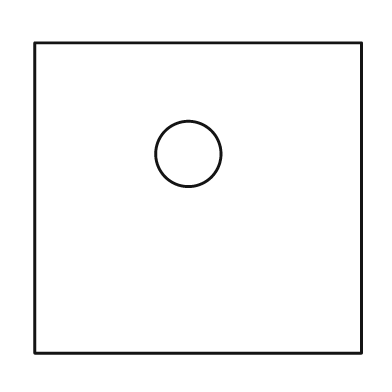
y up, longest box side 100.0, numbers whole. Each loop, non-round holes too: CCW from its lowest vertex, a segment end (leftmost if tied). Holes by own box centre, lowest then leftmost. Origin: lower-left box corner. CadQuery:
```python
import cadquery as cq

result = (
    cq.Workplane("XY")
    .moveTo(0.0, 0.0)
    .lineTo(100.0, 0.0)
    .lineTo(100.0, 95.0)
    .lineTo(0.0, 95.0)
    .close()
    .moveTo(47.0, 61.0)
    .circle(10.0)
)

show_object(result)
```